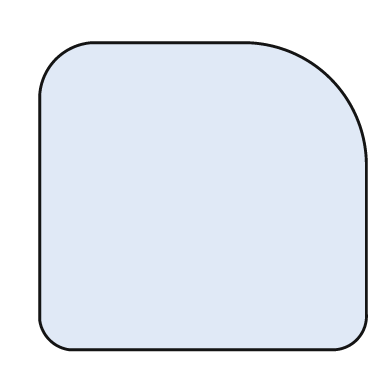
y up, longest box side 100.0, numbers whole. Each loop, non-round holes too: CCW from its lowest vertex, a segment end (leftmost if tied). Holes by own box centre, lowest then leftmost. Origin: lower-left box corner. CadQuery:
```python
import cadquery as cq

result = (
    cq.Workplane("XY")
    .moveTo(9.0, 0.0)
    .lineTo(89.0, 0.0)
    .threePointArc((97.0, 3.0), (100.0, 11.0))
    .lineTo(100.0, 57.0)
    .threePointArc((89.0, 83.0), (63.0, 94.0))
    .lineTo(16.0, 94.0)
    .threePointArc((5.0, 89.0), (0.0, 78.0))
    .lineTo(0.0, 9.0)
    .threePointArc((3.0, 3.0), (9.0, 0.0))
    .close()
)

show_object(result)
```